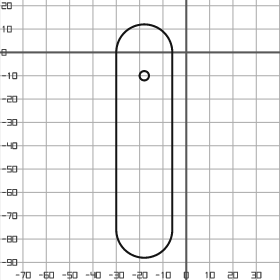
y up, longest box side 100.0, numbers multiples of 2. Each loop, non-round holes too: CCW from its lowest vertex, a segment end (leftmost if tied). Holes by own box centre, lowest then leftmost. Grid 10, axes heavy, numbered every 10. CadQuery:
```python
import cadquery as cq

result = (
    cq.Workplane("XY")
    .moveTo(-30.0, -76.0)
    .threePointArc((-18.0, -88.0), (-6.0, -76.0))
    .lineTo(-6.0, 0.0)
    .threePointArc((-18.0, 12.0), (-30.0, 0.0))
    .close()
    .moveTo(-18.0, -10.0)
    .circle(2.0)
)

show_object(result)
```